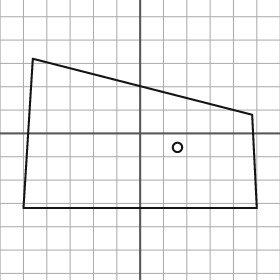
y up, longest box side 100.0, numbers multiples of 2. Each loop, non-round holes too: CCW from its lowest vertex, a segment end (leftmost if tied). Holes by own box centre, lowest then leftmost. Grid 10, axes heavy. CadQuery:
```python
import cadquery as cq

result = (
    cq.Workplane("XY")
    .moveTo(-50.0, -32.0)
    .lineTo(50.0, -32.0)
    .lineTo(48.0, 8.0)
    .lineTo(-46.0, 32.0)
    .close()
    .moveTo(16.0, -6.0)
    .circle(2.0)
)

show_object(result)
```